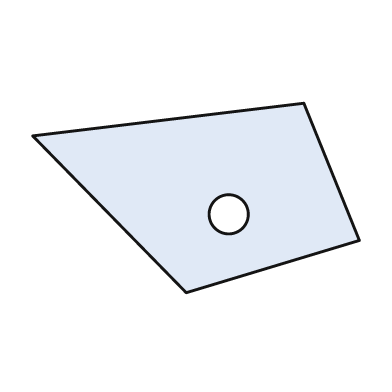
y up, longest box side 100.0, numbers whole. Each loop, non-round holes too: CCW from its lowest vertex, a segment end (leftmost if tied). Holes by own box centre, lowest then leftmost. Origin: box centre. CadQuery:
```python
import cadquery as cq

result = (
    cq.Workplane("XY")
    .moveTo(-3.0, -29.0)
    .lineTo(50.0, -13.0)
    .lineTo(33.0, 29.0)
    .lineTo(-50.0, 19.0)
    .close()
    .moveTo(10.0, -5.0)
    .circle(6.0)
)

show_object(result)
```